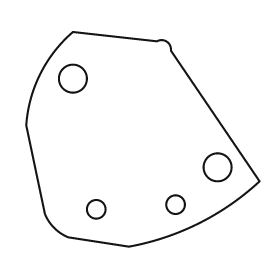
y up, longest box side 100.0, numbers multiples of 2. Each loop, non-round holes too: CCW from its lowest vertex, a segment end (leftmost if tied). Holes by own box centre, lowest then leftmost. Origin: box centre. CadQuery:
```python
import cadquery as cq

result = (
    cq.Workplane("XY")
    .moveTo(-6.0, -46.0)
    .threePointArc((24.0, -36.0), (50.0, -18.0))
    .lineTo(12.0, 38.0)
    .threePointArc((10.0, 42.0), (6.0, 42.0))
    .lineTo(-30.0, 46.0)
    .threePointArc((-44.0, 28.0), (-50.0, 6.0))
    .lineTo(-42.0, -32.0)
    .threePointArc((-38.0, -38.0), (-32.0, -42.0))
    .close()
    .moveTo(-20.0, -30.0)
    .circle(4.0)
    .moveTo(14.0, -28.0)
    .circle(4.0)
    .moveTo(32.0, -12.0)
    .circle(6.0)
    .moveTo(-30.0, 26.0)
    .circle(6.0)
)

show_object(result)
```